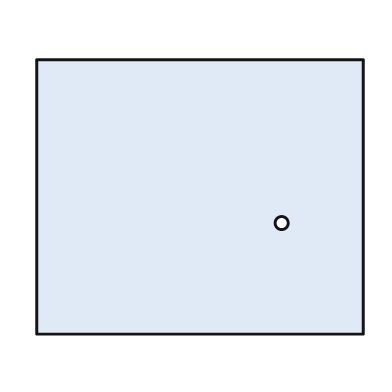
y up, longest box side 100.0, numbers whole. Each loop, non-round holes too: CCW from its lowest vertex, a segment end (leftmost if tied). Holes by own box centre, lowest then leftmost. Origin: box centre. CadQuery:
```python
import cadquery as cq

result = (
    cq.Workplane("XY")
    .moveTo(-50.0, -42.0)
    .lineTo(50.0, -42.0)
    .lineTo(50.0, 42.0)
    .lineTo(-50.0, 42.0)
    .close()
    .moveTo(25.0, -8.0)
    .circle(2.0)
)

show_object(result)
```